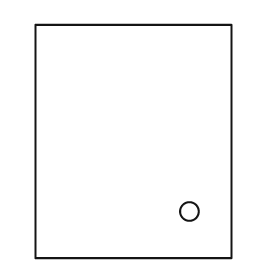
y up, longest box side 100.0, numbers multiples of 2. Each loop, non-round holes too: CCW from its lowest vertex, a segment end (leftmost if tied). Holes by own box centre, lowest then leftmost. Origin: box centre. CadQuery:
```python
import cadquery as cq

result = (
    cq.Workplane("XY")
    .moveTo(-42.0, -50.0)
    .lineTo(42.0, -50.0)
    .lineTo(42.0, 50.0)
    .lineTo(-42.0, 50.0)
    .close()
    .moveTo(24.0, -30.0)
    .circle(4.0)
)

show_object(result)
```